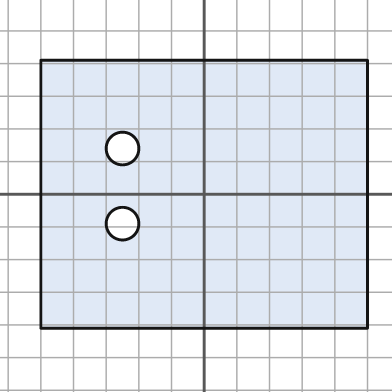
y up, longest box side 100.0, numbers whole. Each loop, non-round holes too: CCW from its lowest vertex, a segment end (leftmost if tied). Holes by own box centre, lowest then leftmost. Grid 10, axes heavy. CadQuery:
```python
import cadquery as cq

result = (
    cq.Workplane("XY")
    .moveTo(-50.0, -41.0)
    .lineTo(50.0, -41.0)
    .lineTo(50.0, 41.0)
    .lineTo(-50.0, 41.0)
    .close()
    .moveTo(-25.0, -9.0)
    .circle(5.0)
    .moveTo(-25.0, 14.0)
    .circle(5.0)
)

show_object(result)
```